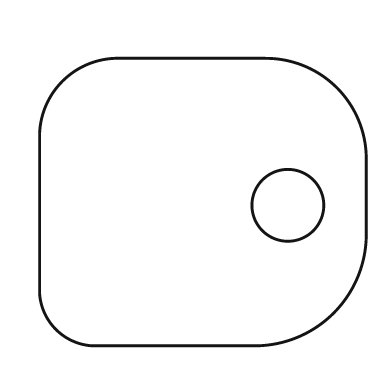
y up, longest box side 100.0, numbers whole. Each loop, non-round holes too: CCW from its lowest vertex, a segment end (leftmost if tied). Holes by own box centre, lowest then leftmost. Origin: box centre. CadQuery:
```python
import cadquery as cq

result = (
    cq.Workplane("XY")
    .moveTo(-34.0, -44.0)
    .lineTo(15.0, -44.0)
    .threePointArc((40.0, -34.0), (50.0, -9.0))
    .lineTo(50.0, 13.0)
    .threePointArc((41.0, 35.0), (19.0, 44.0))
    .lineTo(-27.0, 44.0)
    .threePointArc((-43.0, 37.0), (-50.0, 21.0))
    .lineTo(-50.0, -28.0)
    .threePointArc((-45.0, -39.0), (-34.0, -44.0))
    .close()
    .moveTo(26.0, -1.0)
    .circle(11.0)
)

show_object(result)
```